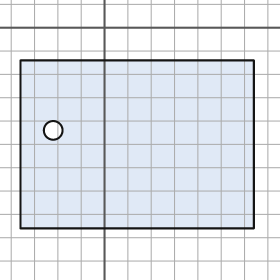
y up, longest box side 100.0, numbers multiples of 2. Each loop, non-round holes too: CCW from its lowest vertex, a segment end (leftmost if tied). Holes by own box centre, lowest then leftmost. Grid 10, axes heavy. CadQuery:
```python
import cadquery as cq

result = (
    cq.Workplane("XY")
    .moveTo(-36.0, -86.0)
    .lineTo(64.0, -86.0)
    .lineTo(64.0, -14.0)
    .lineTo(-36.0, -14.0)
    .close()
    .moveTo(-22.0, -44.0)
    .circle(4.0)
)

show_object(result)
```